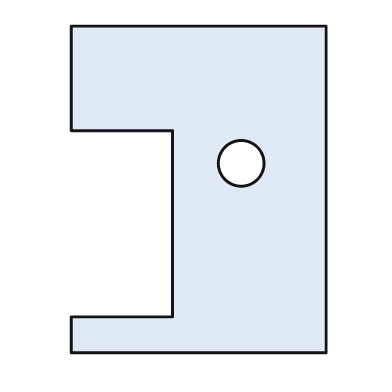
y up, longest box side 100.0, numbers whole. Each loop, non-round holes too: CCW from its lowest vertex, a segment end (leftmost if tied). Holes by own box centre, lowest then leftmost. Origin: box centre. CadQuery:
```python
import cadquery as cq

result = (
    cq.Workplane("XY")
    .moveTo(-39.0, -50.0)
    .lineTo(39.0, -50.0)
    .lineTo(39.0, 50.0)
    .lineTo(-39.0, 50.0)
    .lineTo(-39.0, 18.0)
    .lineTo(-8.0, 18.0)
    .lineTo(-8.0, -39.0)
    .lineTo(-39.0, -39.0)
    .close()
    .moveTo(13.0, 8.0)
    .circle(7.0)
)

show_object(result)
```